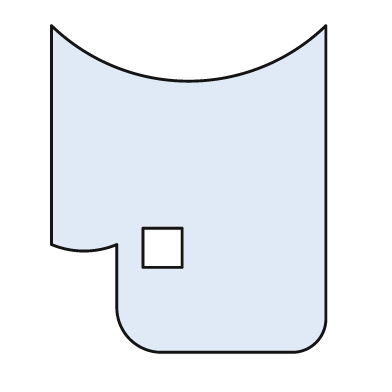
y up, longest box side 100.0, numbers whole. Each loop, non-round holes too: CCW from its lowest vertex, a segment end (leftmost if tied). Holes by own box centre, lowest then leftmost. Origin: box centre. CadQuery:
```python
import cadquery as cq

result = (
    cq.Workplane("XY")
    .moveTo(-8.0, -50.0)
    .lineTo(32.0, -50.0)
    .threePointArc((39.0, -47.0), (42.0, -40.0))
    .lineTo(42.0, 50.0)
    .threePointArc((0.0, 33.0), (-42.0, 50.0))
    .lineTo(-42.0, -17.0)
    .threePointArc((-32.0, -19.0), (-22.0, -17.0))
    .lineTo(-22.0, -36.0)
    .threePointArc((-18.0, -46.0), (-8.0, -50.0))
    .close()
    .moveTo(-14.0, -24.0)
    .lineTo(-2.0, -24.0)
    .lineTo(-2.0, -12.0)
    .lineTo(-14.0, -12.0)
    .close()
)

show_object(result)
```